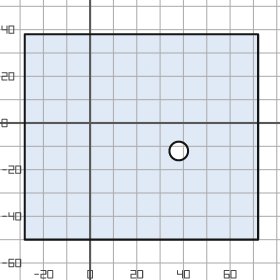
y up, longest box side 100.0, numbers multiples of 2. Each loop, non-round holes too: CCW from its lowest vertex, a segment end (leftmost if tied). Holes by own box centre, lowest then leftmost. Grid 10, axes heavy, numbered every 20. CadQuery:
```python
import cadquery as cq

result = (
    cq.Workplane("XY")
    .moveTo(-28.0, -50.0)
    .lineTo(72.0, -50.0)
    .lineTo(72.0, 38.0)
    .lineTo(-28.0, 38.0)
    .close()
    .moveTo(38.0, -12.0)
    .circle(4.0)
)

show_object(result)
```